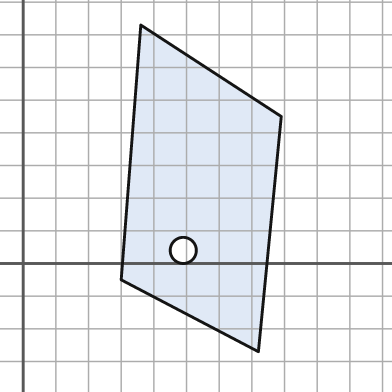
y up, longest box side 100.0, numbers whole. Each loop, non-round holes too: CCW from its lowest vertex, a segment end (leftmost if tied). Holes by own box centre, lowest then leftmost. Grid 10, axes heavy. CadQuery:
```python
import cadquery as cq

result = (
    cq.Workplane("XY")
    .moveTo(72.0, -27.0)
    .lineTo(79.0, 45.0)
    .lineTo(36.0, 73.0)
    .lineTo(30.0, -5.0)
    .close()
    .moveTo(49.0, 4.0)
    .circle(4.0)
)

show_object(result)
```